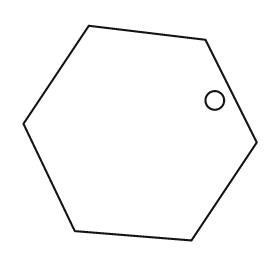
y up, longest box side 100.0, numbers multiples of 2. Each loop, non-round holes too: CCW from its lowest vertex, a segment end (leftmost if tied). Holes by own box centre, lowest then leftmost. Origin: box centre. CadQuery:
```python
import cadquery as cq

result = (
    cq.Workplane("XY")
    .moveTo(22.0, -46.0)
    .lineTo(50.0, -4.0)
    .lineTo(28.0, 40.0)
    .lineTo(-22.0, 46.0)
    .lineTo(-50.0, 4.0)
    .lineTo(-28.0, -42.0)
    .close()
    .moveTo(32.0, 14.0)
    .circle(4.0)
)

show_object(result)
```